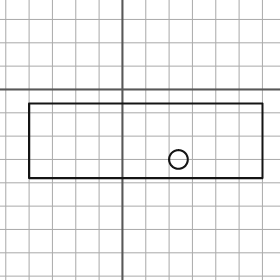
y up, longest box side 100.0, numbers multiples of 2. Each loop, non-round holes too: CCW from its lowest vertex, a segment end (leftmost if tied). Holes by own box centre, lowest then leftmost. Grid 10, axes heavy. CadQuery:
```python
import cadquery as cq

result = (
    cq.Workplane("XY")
    .moveTo(-40.0, -38.0)
    .lineTo(60.0, -38.0)
    .lineTo(60.0, -6.0)
    .lineTo(-40.0, -6.0)
    .close()
    .moveTo(24.0, -30.0)
    .circle(4.0)
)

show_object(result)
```